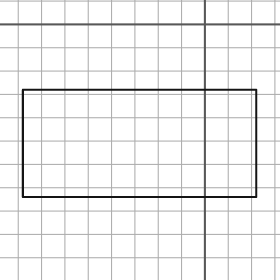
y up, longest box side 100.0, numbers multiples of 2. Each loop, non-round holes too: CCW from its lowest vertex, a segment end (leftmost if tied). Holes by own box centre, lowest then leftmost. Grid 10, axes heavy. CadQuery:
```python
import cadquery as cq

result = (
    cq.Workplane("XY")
    .moveTo(-78.0, -74.0)
    .lineTo(22.0, -74.0)
    .lineTo(22.0, -28.0)
    .lineTo(-78.0, -28.0)
    .close()
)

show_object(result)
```